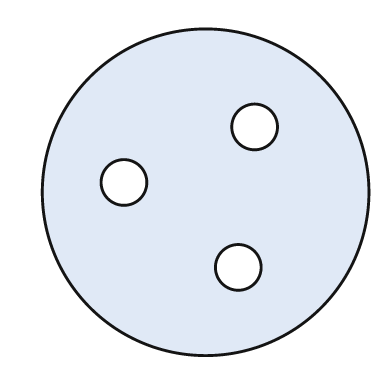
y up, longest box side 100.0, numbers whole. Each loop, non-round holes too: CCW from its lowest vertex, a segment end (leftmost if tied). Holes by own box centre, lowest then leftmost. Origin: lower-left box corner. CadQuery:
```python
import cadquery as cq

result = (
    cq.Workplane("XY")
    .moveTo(50.0, 50.0)
    .circle(50.0)
    .moveTo(60.0, 27.0)
    .circle(7.0)
    .moveTo(25.0, 53.0)
    .circle(7.0)
    .moveTo(65.0, 70.0)
    .circle(7.0)
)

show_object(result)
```